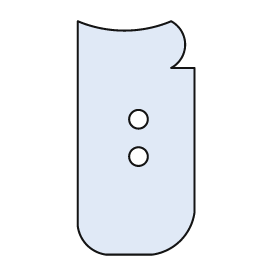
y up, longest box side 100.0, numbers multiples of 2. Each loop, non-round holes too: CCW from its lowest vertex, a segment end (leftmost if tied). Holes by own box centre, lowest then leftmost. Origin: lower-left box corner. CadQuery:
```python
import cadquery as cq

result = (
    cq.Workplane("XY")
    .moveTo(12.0, 0.0)
    .lineTo(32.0, 0.0)
    .threePointArc((44.0, 6.0), (50.0, 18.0))
    .lineTo(50.0, 80.0)
    .lineTo(40.0, 80.0)
    .threePointArc((46.0, 90.0), (40.0, 100.0))
    .threePointArc((20.0, 96.0), (0.0, 100.0))
    .lineTo(0.0, 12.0)
    .threePointArc((4.0, 4.0), (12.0, 0.0))
    .close()
    .moveTo(26.0, 42.0)
    .circle(4.0)
    .moveTo(26.0, 58.0)
    .circle(4.0)
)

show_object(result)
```